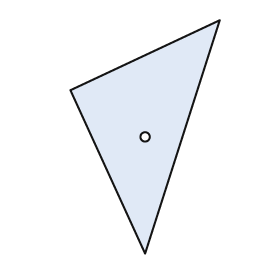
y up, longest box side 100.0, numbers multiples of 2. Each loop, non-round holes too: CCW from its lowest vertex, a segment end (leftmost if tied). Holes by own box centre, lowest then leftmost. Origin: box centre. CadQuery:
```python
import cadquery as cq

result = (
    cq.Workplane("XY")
    .moveTo(0.0, -50.0)
    .lineTo(32.0, 50.0)
    .lineTo(-32.0, 20.0)
    .close()
    .moveTo(0.0, 0.0)
    .circle(2.0)
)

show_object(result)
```